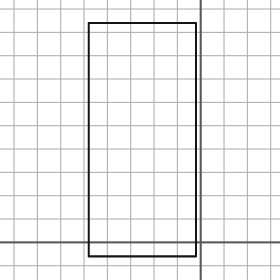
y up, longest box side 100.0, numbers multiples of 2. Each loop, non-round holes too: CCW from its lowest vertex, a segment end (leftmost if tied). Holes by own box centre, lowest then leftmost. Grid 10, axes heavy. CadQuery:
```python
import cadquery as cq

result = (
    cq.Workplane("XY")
    .moveTo(-48.0, -6.0)
    .lineTo(-2.0, -6.0)
    .lineTo(-2.0, 94.0)
    .lineTo(-48.0, 94.0)
    .close()
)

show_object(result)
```